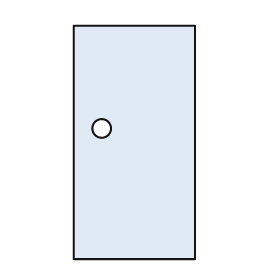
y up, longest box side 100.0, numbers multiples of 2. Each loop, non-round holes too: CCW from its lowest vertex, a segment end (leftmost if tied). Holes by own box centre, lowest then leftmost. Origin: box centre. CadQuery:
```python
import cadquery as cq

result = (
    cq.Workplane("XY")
    .moveTo(-26.0, -50.0)
    .lineTo(26.0, -50.0)
    .lineTo(26.0, 50.0)
    .lineTo(-26.0, 50.0)
    .close()
    .moveTo(-14.0, 6.0)
    .circle(4.0)
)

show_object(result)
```